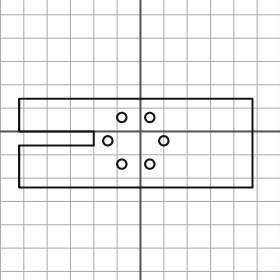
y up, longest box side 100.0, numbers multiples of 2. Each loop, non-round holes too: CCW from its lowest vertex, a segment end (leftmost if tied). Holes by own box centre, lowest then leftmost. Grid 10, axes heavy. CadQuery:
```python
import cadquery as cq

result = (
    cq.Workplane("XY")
    .moveTo(-52.0, -24.0)
    .lineTo(48.0, -24.0)
    .lineTo(48.0, 14.0)
    .lineTo(-52.0, 14.0)
    .lineTo(-52.0, 0.0)
    .lineTo(-20.0, 0.0)
    .lineTo(-20.0, -6.0)
    .lineTo(-52.0, -6.0)
    .close()
    .moveTo(-8.0, -14.0)
    .circle(2.0)
    .moveTo(4.0, -14.0)
    .circle(2.0)
    .moveTo(-14.0, -4.0)
    .circle(2.0)
    .moveTo(10.0, -4.0)
    .circle(2.0)
    .moveTo(-8.0, 6.0)
    .circle(2.0)
    .moveTo(4.0, 6.0)
    .circle(2.0)
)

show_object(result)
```